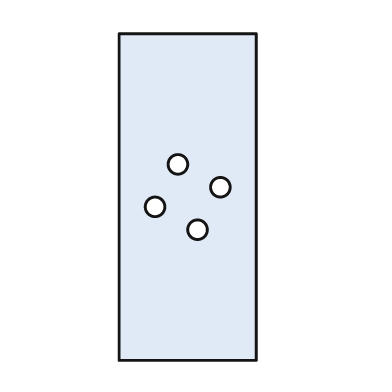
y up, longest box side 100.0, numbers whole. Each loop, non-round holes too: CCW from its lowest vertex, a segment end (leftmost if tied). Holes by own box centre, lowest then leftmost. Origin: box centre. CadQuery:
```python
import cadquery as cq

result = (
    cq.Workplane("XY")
    .moveTo(-21.0, -50.0)
    .lineTo(21.0, -50.0)
    .lineTo(21.0, 50.0)
    .lineTo(-21.0, 50.0)
    .close()
    .moveTo(3.0, -10.0)
    .circle(3.0)
    .moveTo(-10.0, -3.0)
    .circle(3.0)
    .moveTo(10.0, 3.0)
    .circle(3.0)
    .moveTo(-3.0, 10.0)
    .circle(3.0)
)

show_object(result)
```